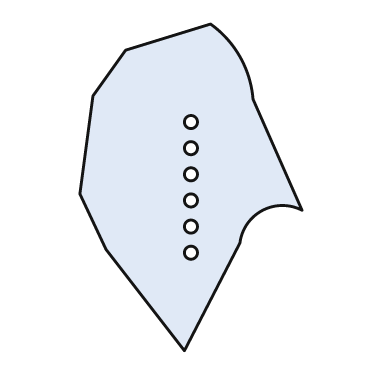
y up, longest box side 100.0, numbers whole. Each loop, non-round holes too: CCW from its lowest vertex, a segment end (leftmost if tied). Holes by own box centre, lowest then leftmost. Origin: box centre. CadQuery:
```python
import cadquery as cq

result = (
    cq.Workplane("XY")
    .moveTo(-2.0, -50.0)
    .lineTo(15.0, -17.0)
    .threePointArc((22.0, -7.0), (34.0, -7.0))
    .lineTo(19.0, 27.0)
    .threePointArc((15.0, 40.0), (6.0, 50.0))
    .lineTo(-20.0, 42.0)
    .lineTo(-30.0, 28.0)
    .lineTo(-34.0, -2.0)
    .lineTo(-26.0, -19.0)
    .close()
    .moveTo(0.0, -20.0)
    .circle(2.0)
    .moveTo(0.0, -12.0)
    .circle(2.0)
    .moveTo(0.0, -4.0)
    .circle(2.0)
    .moveTo(0.0, 4.0)
    .circle(2.0)
    .moveTo(0.0, 12.0)
    .circle(2.0)
    .moveTo(0.0, 20.0)
    .circle(2.0)
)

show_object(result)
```